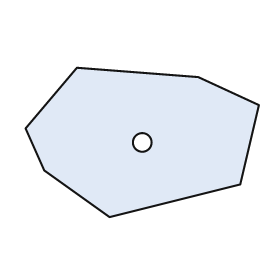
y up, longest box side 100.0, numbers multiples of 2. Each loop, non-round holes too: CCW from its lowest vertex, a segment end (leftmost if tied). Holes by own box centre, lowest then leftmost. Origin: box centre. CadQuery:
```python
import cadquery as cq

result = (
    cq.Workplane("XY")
    .moveTo(-14.0, -32.0)
    .lineTo(42.0, -18.0)
    .lineTo(50.0, 16.0)
    .lineTo(24.0, 28.0)
    .lineTo(-28.0, 32.0)
    .lineTo(-50.0, 6.0)
    .lineTo(-42.0, -12.0)
    .close()
    .moveTo(0.0, 0.0)
    .circle(4.0)
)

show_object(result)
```